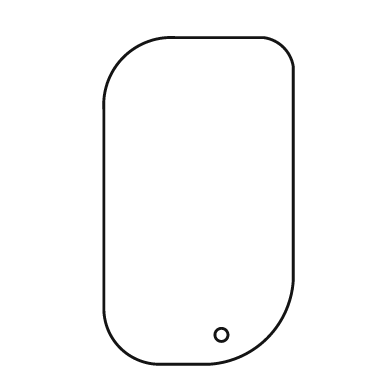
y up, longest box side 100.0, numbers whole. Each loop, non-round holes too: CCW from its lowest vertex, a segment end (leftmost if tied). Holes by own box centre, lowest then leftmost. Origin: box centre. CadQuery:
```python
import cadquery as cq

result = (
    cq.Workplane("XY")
    .moveTo(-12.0, -50.0)
    .lineTo(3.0, -50.0)
    .threePointArc((21.0, -42.0), (29.0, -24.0))
    .lineTo(29.0, 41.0)
    .threePointArc((26.0, 47.0), (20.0, 50.0))
    .lineTo(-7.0, 50.0)
    .threePointArc((-23.0, 44.0), (-29.0, 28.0))
    .lineTo(-29.0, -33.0)
    .threePointArc((-24.0, -45.0), (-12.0, -50.0))
    .close()
    .moveTo(7.0, -41.0)
    .circle(2.0)
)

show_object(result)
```